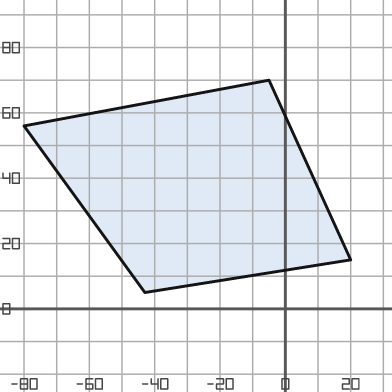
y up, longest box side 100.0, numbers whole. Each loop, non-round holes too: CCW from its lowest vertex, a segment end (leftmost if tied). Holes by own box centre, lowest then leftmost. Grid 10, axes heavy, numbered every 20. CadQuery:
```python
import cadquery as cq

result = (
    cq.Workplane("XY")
    .moveTo(-43.0, 5.0)
    .lineTo(20.0, 15.0)
    .lineTo(-5.0, 70.0)
    .lineTo(-80.0, 56.0)
    .close()
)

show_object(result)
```